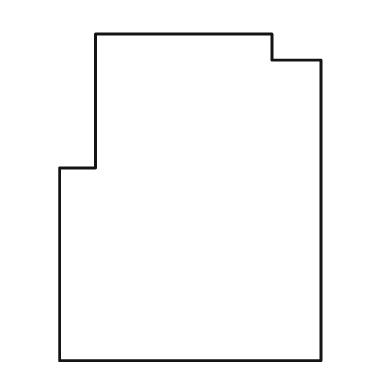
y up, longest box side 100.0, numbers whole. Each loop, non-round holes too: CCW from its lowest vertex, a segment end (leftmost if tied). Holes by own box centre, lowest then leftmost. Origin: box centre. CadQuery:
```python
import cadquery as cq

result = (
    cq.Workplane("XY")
    .moveTo(-40.0, -50.0)
    .lineTo(40.0, -50.0)
    .lineTo(40.0, 42.0)
    .lineTo(25.0, 42.0)
    .lineTo(25.0, 50.0)
    .lineTo(-29.0, 50.0)
    .lineTo(-29.0, 9.0)
    .lineTo(-40.0, 9.0)
    .close()
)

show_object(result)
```